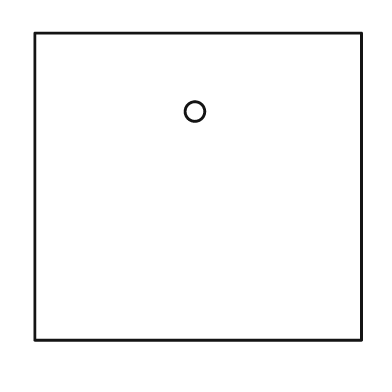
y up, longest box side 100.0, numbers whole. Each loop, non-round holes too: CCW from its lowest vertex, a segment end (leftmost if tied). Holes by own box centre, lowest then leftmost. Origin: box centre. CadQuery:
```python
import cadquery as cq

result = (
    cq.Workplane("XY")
    .moveTo(-50.0, -47.0)
    .lineTo(50.0, -47.0)
    .lineTo(50.0, 47.0)
    .lineTo(-50.0, 47.0)
    .close()
    .moveTo(-1.0, 23.0)
    .circle(3.0)
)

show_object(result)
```